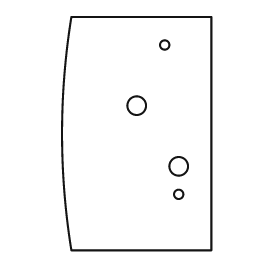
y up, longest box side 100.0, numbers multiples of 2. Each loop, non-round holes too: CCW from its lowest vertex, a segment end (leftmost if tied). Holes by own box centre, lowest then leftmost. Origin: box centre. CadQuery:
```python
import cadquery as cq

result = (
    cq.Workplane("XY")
    .moveTo(-28.0, -50.0)
    .lineTo(32.0, -50.0)
    .lineTo(32.0, 50.0)
    .lineTo(-28.0, 50.0)
    .threePointArc((-32.0, 0.0), (-28.0, -50.0))
    .close()
    .moveTo(18.0, -26.0)
    .circle(2.0)
    .moveTo(18.0, -14.0)
    .circle(4.0)
    .moveTo(0.0, 12.0)
    .circle(4.0)
    .moveTo(12.0, 38.0)
    .circle(2.0)
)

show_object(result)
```